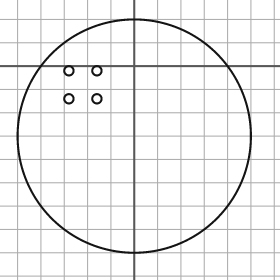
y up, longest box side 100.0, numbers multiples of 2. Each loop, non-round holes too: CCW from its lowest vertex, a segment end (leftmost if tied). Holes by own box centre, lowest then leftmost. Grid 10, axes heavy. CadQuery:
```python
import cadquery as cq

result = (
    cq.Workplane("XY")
    .moveTo(0.0, -30.0)
    .circle(50.0)
    .moveTo(-28.0, -14.0)
    .circle(2.0)
    .moveTo(-16.0, -14.0)
    .circle(2.0)
    .moveTo(-28.0, -2.0)
    .circle(2.0)
    .moveTo(-16.0, -2.0)
    .circle(2.0)
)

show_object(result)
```